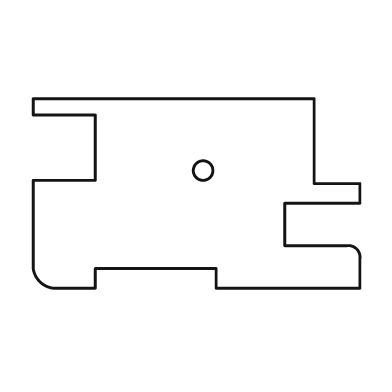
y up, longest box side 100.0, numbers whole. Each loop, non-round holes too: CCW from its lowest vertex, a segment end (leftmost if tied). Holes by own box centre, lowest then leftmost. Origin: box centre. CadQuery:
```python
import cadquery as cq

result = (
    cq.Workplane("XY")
    .moveTo(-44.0, -29.0)
    .lineTo(-31.0, -29.0)
    .lineTo(-31.0, -23.0)
    .lineTo(6.0, -23.0)
    .lineTo(6.0, -29.0)
    .lineTo(50.0, -29.0)
    .lineTo(50.0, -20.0)
    .threePointArc((49.0, -17.0), (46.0, -16.0))
    .lineTo(27.0, -16.0)
    .lineTo(27.0, -3.0)
    .lineTo(50.0, -3.0)
    .lineTo(50.0, 3.0)
    .lineTo(36.0, 3.0)
    .lineTo(36.0, 29.0)
    .lineTo(-50.0, 29.0)
    .lineTo(-50.0, 24.0)
    .lineTo(-31.0, 24.0)
    .lineTo(-31.0, 4.0)
    .lineTo(-50.0, 4.0)
    .lineTo(-50.0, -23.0)
    .threePointArc((-48.0, -27.0), (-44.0, -29.0))
    .close()
    .moveTo(2.0, 7.0)
    .circle(3.0)
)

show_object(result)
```